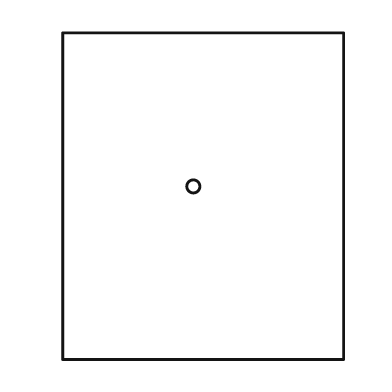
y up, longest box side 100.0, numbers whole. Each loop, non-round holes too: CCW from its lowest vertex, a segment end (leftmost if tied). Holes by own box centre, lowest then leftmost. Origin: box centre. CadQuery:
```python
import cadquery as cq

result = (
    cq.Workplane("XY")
    .moveTo(-43.0, -50.0)
    .lineTo(43.0, -50.0)
    .lineTo(43.0, 50.0)
    .lineTo(-43.0, 50.0)
    .close()
    .moveTo(-3.0, 3.0)
    .circle(2.0)
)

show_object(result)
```